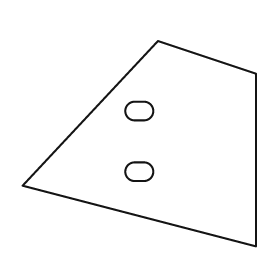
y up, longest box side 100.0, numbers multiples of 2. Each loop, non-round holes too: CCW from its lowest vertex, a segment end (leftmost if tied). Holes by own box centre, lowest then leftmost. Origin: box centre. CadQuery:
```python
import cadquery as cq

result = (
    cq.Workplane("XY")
    .moveTo(50.0, -44.0)
    .lineTo(50.0, 30.0)
    .lineTo(8.0, 44.0)
    .lineTo(-50.0, -18.0)
    .close()
    .moveTo(-2.0, -16.0)
    .lineTo(2.0, -16.0)
    .threePointArc((6.0, -12.0), (2.0, -8.0))
    .lineTo(-2.0, -8.0)
    .threePointArc((-6.0, -12.0), (-2.0, -16.0))
    .close()
    .moveTo(-2.0, 10.0)
    .lineTo(2.0, 10.0)
    .threePointArc((6.0, 14.0), (2.0, 18.0))
    .lineTo(-2.0, 18.0)
    .threePointArc((-6.0, 14.0), (-2.0, 10.0))
    .close()
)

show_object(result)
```